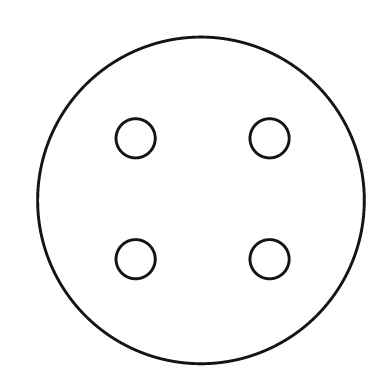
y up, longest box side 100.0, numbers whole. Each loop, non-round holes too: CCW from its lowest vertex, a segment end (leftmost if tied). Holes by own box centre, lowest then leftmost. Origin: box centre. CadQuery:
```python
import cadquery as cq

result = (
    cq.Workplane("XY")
    .moveTo(0.0, 0.0)
    .circle(50.0)
    .moveTo(-20.0, -18.0)
    .circle(6.0)
    .moveTo(21.0, -18.0)
    .circle(6.0)
    .moveTo(-20.0, 19.0)
    .circle(6.0)
    .moveTo(21.0, 19.0)
    .circle(6.0)
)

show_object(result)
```